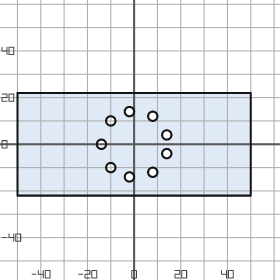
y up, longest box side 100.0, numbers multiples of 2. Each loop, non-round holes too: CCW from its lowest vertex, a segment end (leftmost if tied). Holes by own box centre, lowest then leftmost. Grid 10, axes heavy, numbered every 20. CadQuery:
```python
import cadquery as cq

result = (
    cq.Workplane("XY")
    .moveTo(-50.0, -22.0)
    .lineTo(50.0, -22.0)
    .lineTo(50.0, 22.0)
    .lineTo(-50.0, 22.0)
    .close()
    .moveTo(-2.0, -14.0)
    .circle(2.0)
    .moveTo(8.0, -12.0)
    .circle(2.0)
    .moveTo(-10.0, -10.0)
    .circle(2.0)
    .moveTo(14.0, -4.0)
    .circle(2.0)
    .moveTo(-14.0, 0.0)
    .circle(2.0)
    .moveTo(14.0, 4.0)
    .circle(2.0)
    .moveTo(-10.0, 10.0)
    .circle(2.0)
    .moveTo(8.0, 12.0)
    .circle(2.0)
    .moveTo(-2.0, 14.0)
    .circle(2.0)
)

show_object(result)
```